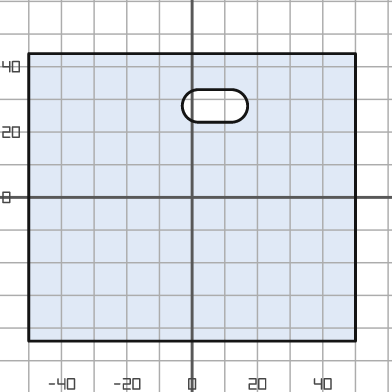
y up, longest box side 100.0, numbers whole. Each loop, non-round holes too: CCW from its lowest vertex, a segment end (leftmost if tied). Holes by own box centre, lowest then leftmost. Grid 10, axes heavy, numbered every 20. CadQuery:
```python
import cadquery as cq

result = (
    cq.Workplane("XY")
    .moveTo(-50.0, -44.0)
    .lineTo(50.0, -44.0)
    .lineTo(50.0, 44.0)
    .lineTo(-50.0, 44.0)
    .close()
    .moveTo(2.0, 23.0)
    .lineTo(12.0, 23.0)
    .threePointArc((17.0, 28.0), (12.0, 33.0))
    .lineTo(2.0, 33.0)
    .threePointArc((-3.0, 28.0), (2.0, 23.0))
    .close()
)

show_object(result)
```